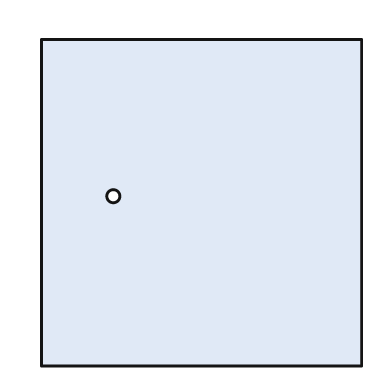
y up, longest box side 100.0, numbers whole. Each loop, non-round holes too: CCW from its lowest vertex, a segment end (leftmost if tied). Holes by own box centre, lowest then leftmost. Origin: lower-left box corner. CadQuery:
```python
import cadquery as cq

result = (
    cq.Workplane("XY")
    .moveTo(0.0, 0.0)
    .lineTo(98.0, 0.0)
    .lineTo(98.0, 100.0)
    .lineTo(0.0, 100.0)
    .close()
    .moveTo(22.0, 52.0)
    .circle(2.0)
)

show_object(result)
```